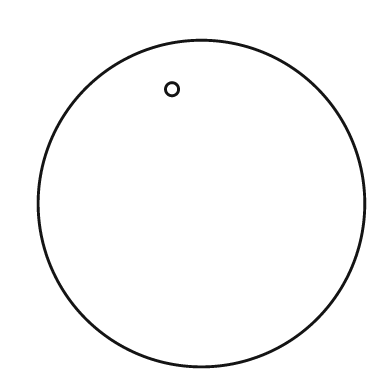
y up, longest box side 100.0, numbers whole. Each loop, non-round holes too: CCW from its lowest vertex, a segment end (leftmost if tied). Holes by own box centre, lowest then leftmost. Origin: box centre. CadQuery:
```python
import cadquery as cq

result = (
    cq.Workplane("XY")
    .moveTo(0.0, 0.0)
    .circle(50.0)
    .moveTo(-9.0, 35.0)
    .circle(2.0)
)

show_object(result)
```